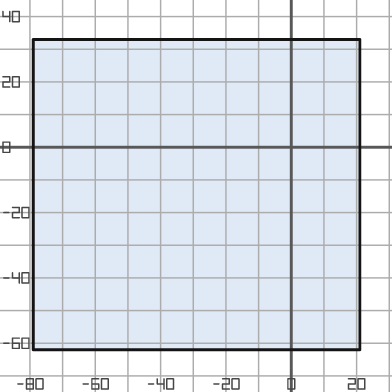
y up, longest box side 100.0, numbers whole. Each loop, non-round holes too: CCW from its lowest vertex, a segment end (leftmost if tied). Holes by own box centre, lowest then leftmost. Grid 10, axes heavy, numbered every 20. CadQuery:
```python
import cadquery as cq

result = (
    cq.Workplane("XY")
    .moveTo(-79.0, -62.0)
    .lineTo(21.0, -62.0)
    .lineTo(21.0, 33.0)
    .lineTo(-79.0, 33.0)
    .close()
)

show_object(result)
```